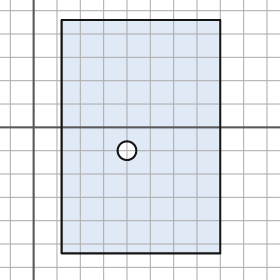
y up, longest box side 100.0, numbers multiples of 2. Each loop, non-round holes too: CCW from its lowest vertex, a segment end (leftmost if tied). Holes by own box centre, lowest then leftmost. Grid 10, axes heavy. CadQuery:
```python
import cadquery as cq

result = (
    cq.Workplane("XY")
    .moveTo(12.0, -54.0)
    .lineTo(80.0, -54.0)
    .lineTo(80.0, 46.0)
    .lineTo(12.0, 46.0)
    .close()
    .moveTo(40.0, -10.0)
    .circle(4.0)
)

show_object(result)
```